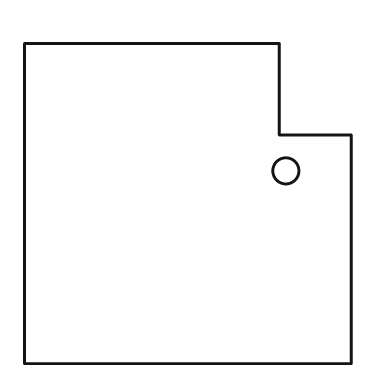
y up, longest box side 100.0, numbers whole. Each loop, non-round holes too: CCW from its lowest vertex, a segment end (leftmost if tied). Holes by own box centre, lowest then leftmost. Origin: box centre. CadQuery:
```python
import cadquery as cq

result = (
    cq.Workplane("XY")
    .moveTo(-50.0, -49.0)
    .lineTo(50.0, -49.0)
    .lineTo(50.0, 21.0)
    .lineTo(28.0, 21.0)
    .lineTo(28.0, 49.0)
    .lineTo(-50.0, 49.0)
    .close()
    .moveTo(30.0, 10.0)
    .circle(4.0)
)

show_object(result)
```